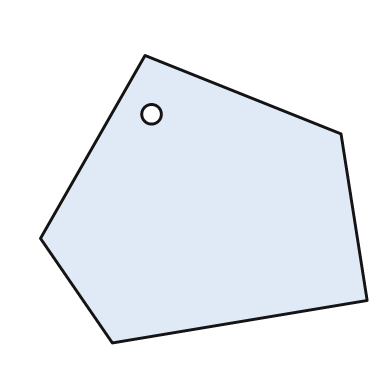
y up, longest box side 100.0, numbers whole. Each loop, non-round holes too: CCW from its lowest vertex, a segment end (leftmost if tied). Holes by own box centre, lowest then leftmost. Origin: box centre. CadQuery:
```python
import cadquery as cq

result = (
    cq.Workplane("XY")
    .moveTo(-28.0, -44.0)
    .lineTo(50.0, -31.0)
    .lineTo(42.0, 20.0)
    .lineTo(-18.0, 44.0)
    .lineTo(-50.0, -12.0)
    .close()
    .moveTo(-16.0, 26.0)
    .circle(3.0)
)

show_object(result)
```